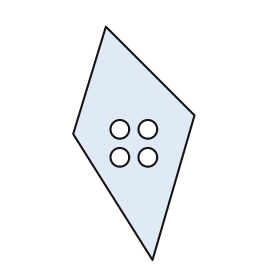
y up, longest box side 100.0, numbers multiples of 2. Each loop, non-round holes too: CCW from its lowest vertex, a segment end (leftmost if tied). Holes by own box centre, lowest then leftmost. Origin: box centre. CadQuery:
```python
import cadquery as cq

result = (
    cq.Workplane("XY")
    .moveTo(8.0, -50.0)
    .lineTo(26.0, 12.0)
    .lineTo(-12.0, 50.0)
    .lineTo(-26.0, 4.0)
    .close()
    .moveTo(-6.0, -6.0)
    .circle(4.0)
    .moveTo(6.0, -6.0)
    .circle(4.0)
    .moveTo(-6.0, 6.0)
    .circle(4.0)
    .moveTo(6.0, 6.0)
    .circle(4.0)
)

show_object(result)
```